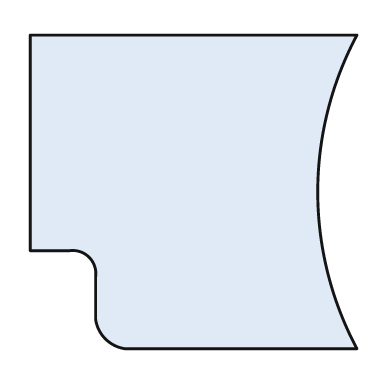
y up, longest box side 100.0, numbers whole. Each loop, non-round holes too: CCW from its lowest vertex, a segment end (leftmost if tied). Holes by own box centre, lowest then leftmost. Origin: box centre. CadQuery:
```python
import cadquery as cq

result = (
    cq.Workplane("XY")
    .moveTo(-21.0, -48.0)
    .lineTo(50.0, -48.0)
    .threePointArc((38.0, 0.0), (50.0, 48.0))
    .lineTo(-50.0, 48.0)
    .lineTo(-50.0, -18.0)
    .lineTo(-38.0, -18.0)
    .threePointArc((-32.0, -20.0), (-30.0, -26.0))
    .lineTo(-30.0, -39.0)
    .threePointArc((-27.0, -45.0), (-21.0, -48.0))
    .close()
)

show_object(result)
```